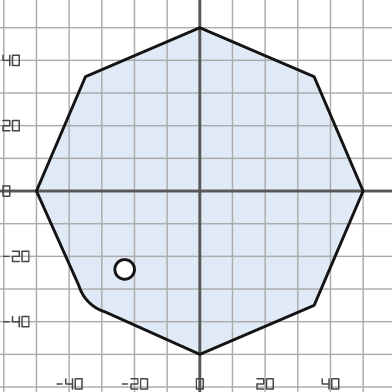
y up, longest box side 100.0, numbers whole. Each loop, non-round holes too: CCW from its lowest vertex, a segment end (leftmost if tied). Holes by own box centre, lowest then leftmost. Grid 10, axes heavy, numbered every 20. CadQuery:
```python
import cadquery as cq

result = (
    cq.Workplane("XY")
    .moveTo(0.0, -50.0)
    .lineTo(35.0, -35.0)
    .lineTo(50.0, 0.0)
    .lineTo(35.0, 35.0)
    .lineTo(0.0, 50.0)
    .lineTo(-35.0, 35.0)
    .lineTo(-50.0, 0.0)
    .lineTo(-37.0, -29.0)
    .threePointArc((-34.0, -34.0), (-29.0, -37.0))
    .close()
    .moveTo(-23.0, -24.0)
    .circle(3.0)
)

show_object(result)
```